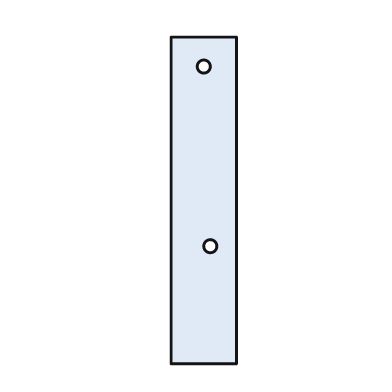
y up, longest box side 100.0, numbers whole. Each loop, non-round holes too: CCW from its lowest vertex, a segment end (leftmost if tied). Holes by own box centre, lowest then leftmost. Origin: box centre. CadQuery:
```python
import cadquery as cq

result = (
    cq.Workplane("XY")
    .moveTo(-10.0, -50.0)
    .lineTo(10.0, -50.0)
    .lineTo(10.0, 50.0)
    .lineTo(-10.0, 50.0)
    .close()
    .moveTo(2.0, -14.0)
    .circle(2.0)
    .moveTo(0.0, 41.0)
    .circle(2.0)
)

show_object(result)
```